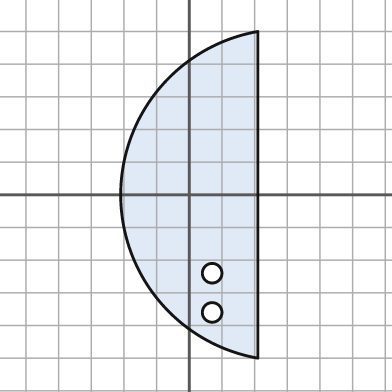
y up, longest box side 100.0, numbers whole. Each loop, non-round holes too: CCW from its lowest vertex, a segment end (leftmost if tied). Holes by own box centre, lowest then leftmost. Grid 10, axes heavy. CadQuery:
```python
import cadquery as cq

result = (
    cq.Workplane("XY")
    .moveTo(21.0, -50.0)
    .lineTo(21.0, 50.0)
    .threePointArc((-21.0, 0.0), (21.0, -50.0))
    .close()
    .moveTo(7.0, -36.0)
    .circle(3.0)
    .moveTo(7.0, -24.0)
    .circle(3.0)
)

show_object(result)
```